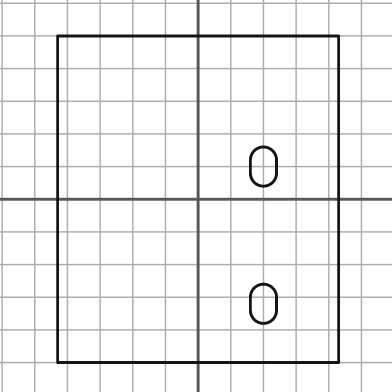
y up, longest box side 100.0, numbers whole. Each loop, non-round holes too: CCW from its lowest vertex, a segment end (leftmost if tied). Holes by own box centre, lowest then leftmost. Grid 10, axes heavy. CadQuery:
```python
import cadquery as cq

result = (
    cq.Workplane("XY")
    .moveTo(-43.0, -50.0)
    .lineTo(43.0, -50.0)
    .lineTo(43.0, 50.0)
    .lineTo(-43.0, 50.0)
    .close()
    .moveTo(16.0, -34.0)
    .threePointArc((20.0, -38.0), (24.0, -34.0))
    .lineTo(24.0, -30.0)
    .threePointArc((20.0, -26.0), (16.0, -30.0))
    .close()
    .moveTo(16.0, 8.0)
    .threePointArc((20.0, 4.0), (24.0, 8.0))
    .lineTo(24.0, 12.0)
    .threePointArc((20.0, 16.0), (16.0, 12.0))
    .close()
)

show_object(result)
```